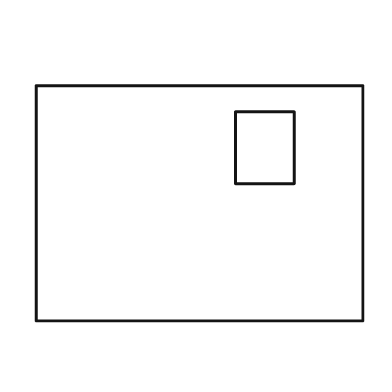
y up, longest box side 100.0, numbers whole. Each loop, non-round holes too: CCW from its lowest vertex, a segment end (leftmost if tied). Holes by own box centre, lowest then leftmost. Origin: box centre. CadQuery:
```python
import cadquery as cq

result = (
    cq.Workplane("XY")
    .moveTo(-50.0, -36.0)
    .lineTo(50.0, -36.0)
    .lineTo(50.0, 36.0)
    .lineTo(-50.0, 36.0)
    .close()
    .moveTo(11.0, 6.0)
    .lineTo(29.0, 6.0)
    .lineTo(29.0, 28.0)
    .lineTo(11.0, 28.0)
    .close()
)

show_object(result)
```